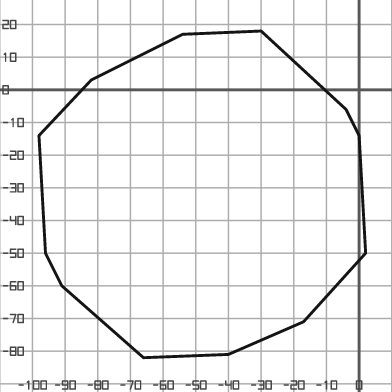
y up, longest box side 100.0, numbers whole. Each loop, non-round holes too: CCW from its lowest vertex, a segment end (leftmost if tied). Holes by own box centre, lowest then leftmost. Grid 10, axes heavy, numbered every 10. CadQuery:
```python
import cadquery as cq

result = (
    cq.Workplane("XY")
    .moveTo(-66.0, -82.0)
    .lineTo(-40.0, -81.0)
    .lineTo(-17.0, -71.0)
    .lineTo(2.0, -50.0)
    .lineTo(0.0, -14.0)
    .lineTo(-4.0, -6.0)
    .lineTo(-30.0, 18.0)
    .lineTo(-54.0, 17.0)
    .lineTo(-82.0, 3.0)
    .lineTo(-98.0, -14.0)
    .lineTo(-96.0, -50.0)
    .lineTo(-91.0, -60.0)
    .close()
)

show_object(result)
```